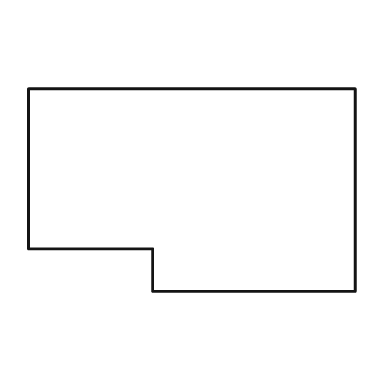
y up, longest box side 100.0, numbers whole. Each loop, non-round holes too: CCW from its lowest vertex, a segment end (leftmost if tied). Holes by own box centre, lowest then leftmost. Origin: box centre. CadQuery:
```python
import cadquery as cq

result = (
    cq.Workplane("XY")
    .moveTo(-12.0, -31.0)
    .lineTo(50.0, -31.0)
    .lineTo(50.0, 31.0)
    .lineTo(-50.0, 31.0)
    .lineTo(-50.0, -18.0)
    .lineTo(-12.0, -18.0)
    .close()
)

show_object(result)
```